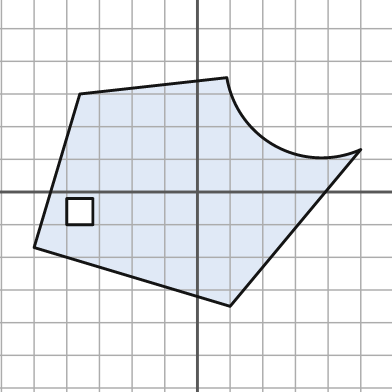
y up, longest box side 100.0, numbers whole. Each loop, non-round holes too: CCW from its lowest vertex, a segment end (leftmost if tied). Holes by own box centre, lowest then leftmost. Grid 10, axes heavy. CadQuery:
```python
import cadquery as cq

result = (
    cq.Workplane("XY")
    .moveTo(10.0, -35.0)
    .lineTo(50.0, 13.0)
    .threePointArc((24.0, 14.0), (9.0, 35.0))
    .lineTo(-36.0, 30.0)
    .lineTo(-50.0, -17.0)
    .close()
    .moveTo(-40.0, -10.0)
    .lineTo(-32.0, -10.0)
    .lineTo(-32.0, -2.0)
    .lineTo(-40.0, -2.0)
    .close()
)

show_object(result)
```